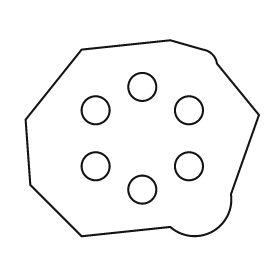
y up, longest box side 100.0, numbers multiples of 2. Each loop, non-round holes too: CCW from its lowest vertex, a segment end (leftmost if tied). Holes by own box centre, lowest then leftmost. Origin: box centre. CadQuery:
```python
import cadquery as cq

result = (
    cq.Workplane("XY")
    .moveTo(-26.0, -42.0)
    .lineTo(12.0, -38.0)
    .threePointArc((30.0, -40.0), (38.0, -24.0))
    .lineTo(50.0, 10.0)
    .lineTo(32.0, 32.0)
    .threePointArc((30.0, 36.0), (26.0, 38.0))
    .lineTo(12.0, 42.0)
    .lineTo(-26.0, 38.0)
    .lineTo(-50.0, 8.0)
    .lineTo(-48.0, -20.0)
    .close()
    .moveTo(0.0, -22.0)
    .circle(6.0)
    .moveTo(-20.0, -12.0)
    .circle(6.0)
    .moveTo(20.0, -12.0)
    .circle(6.0)
    .moveTo(-20.0, 12.0)
    .circle(6.0)
    .moveTo(20.0, 12.0)
    .circle(6.0)
    .moveTo(0.0, 22.0)
    .circle(6.0)
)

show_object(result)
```